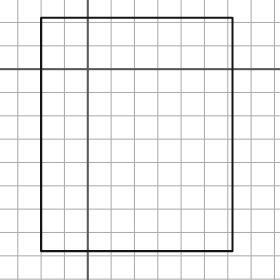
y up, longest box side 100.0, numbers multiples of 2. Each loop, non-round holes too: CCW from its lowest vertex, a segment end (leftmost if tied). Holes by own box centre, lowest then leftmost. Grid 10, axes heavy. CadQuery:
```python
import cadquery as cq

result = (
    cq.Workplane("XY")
    .moveTo(-20.0, -78.0)
    .lineTo(62.0, -78.0)
    .lineTo(62.0, 22.0)
    .lineTo(-20.0, 22.0)
    .close()
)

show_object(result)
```